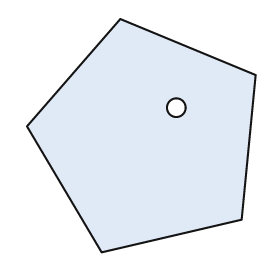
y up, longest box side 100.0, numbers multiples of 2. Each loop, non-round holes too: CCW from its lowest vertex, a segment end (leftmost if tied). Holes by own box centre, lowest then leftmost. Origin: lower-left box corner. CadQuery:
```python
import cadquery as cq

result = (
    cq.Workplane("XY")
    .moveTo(32.0, 0.0)
    .lineTo(92.0, 14.0)
    .lineTo(98.0, 76.0)
    .lineTo(40.0, 100.0)
    .lineTo(0.0, 54.0)
    .close()
    .moveTo(64.0, 62.0)
    .circle(4.0)
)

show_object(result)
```